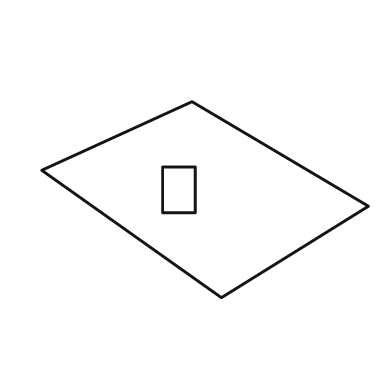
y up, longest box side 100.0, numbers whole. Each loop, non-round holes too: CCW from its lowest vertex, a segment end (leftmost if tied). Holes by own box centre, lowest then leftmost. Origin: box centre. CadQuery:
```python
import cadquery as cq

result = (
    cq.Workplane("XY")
    .moveTo(5.0, -30.0)
    .lineTo(50.0, -2.0)
    .lineTo(-4.0, 30.0)
    .lineTo(-50.0, 9.0)
    .close()
    .moveTo(-13.0, -4.0)
    .lineTo(-3.0, -4.0)
    .lineTo(-3.0, 10.0)
    .lineTo(-13.0, 10.0)
    .close()
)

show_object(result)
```